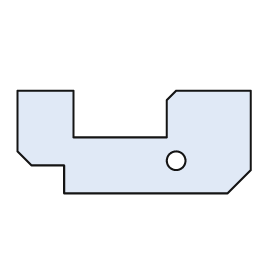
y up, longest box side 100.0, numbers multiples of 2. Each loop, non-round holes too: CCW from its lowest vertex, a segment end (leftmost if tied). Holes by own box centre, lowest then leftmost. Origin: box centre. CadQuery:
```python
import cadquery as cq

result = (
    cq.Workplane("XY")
    .moveTo(-30.0, -22.0)
    .lineTo(40.0, -22.0)
    .lineTo(50.0, -12.0)
    .lineTo(50.0, 22.0)
    .lineTo(18.0, 22.0)
    .lineTo(14.0, 18.0)
    .lineTo(14.0, 2.0)
    .lineTo(-26.0, 2.0)
    .lineTo(-26.0, 22.0)
    .lineTo(-50.0, 22.0)
    .lineTo(-50.0, -4.0)
    .lineTo(-44.0, -10.0)
    .lineTo(-30.0, -10.0)
    .close()
    .moveTo(18.0, -8.0)
    .circle(4.0)
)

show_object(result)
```